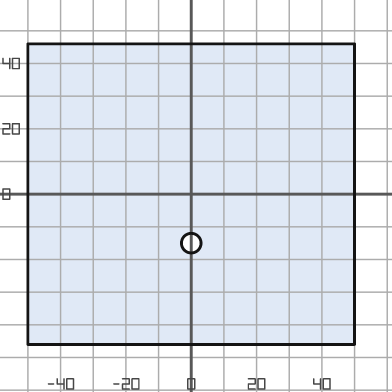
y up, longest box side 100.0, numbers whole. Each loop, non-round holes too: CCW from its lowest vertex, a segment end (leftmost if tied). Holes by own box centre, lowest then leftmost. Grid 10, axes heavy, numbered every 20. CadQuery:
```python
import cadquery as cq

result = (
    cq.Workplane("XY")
    .moveTo(-50.0, -46.0)
    .lineTo(50.0, -46.0)
    .lineTo(50.0, 46.0)
    .lineTo(-50.0, 46.0)
    .close()
    .moveTo(0.0, -15.0)
    .circle(3.0)
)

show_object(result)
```